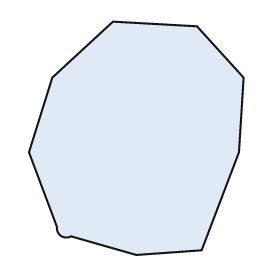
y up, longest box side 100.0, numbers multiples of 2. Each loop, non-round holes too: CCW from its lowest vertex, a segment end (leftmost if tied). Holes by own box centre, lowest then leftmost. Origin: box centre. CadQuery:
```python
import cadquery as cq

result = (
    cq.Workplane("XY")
    .moveTo(0.0, -50.0)
    .lineTo(28.0, -48.0)
    .lineTo(44.0, -6.0)
    .lineTo(46.0, 26.0)
    .lineTo(26.0, 48.0)
    .lineTo(-10.0, 50.0)
    .lineTo(-36.0, 26.0)
    .lineTo(-46.0, -6.0)
    .lineTo(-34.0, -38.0)
    .threePointArc((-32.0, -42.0), (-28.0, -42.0))
    .close()
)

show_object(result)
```